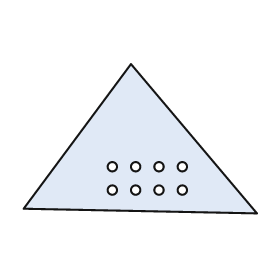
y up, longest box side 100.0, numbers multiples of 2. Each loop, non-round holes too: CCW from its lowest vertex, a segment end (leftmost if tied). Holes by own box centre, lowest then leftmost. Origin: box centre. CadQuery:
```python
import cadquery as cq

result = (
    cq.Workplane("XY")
    .moveTo(50.0, -32.0)
    .lineTo(-4.0, 32.0)
    .lineTo(-50.0, -30.0)
    .close()
    .moveTo(-12.0, -22.0)
    .circle(2.0)
    .moveTo(-2.0, -22.0)
    .circle(2.0)
    .moveTo(8.0, -22.0)
    .circle(2.0)
    .moveTo(18.0, -22.0)
    .circle(2.0)
    .moveTo(-12.0, -12.0)
    .circle(2.0)
    .moveTo(-2.0, -12.0)
    .circle(2.0)
    .moveTo(8.0, -12.0)
    .circle(2.0)
    .moveTo(18.0, -12.0)
    .circle(2.0)
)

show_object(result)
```